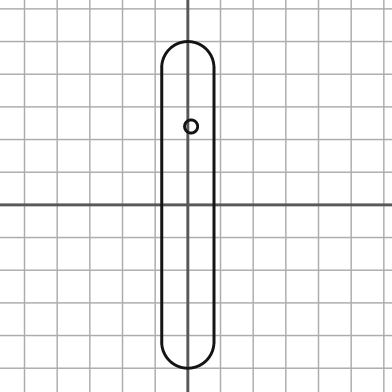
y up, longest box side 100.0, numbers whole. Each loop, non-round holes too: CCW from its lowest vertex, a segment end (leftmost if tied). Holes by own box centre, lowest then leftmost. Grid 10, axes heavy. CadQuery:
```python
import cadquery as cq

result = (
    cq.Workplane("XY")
    .moveTo(-8.0, -42.0)
    .threePointArc((0.0, -50.0), (8.0, -42.0))
    .lineTo(8.0, 42.0)
    .threePointArc((0.0, 50.0), (-8.0, 42.0))
    .close()
    .moveTo(1.0, 24.0)
    .circle(2.0)
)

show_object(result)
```